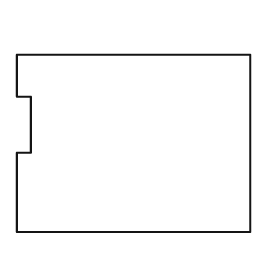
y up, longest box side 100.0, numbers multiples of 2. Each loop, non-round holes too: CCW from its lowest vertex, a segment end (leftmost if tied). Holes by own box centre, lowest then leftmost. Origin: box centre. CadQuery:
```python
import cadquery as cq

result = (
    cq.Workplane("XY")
    .moveTo(-50.0, -38.0)
    .lineTo(50.0, -38.0)
    .lineTo(50.0, 38.0)
    .lineTo(-50.0, 38.0)
    .lineTo(-50.0, 20.0)
    .lineTo(-44.0, 20.0)
    .lineTo(-44.0, -4.0)
    .lineTo(-50.0, -4.0)
    .close()
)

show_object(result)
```